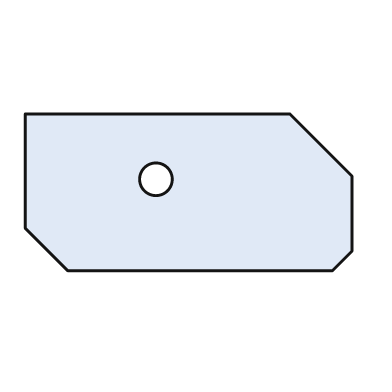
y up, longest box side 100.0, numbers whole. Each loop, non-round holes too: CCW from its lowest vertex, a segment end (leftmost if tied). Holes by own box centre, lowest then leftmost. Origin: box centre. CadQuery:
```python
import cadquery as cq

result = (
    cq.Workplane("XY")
    .moveTo(-37.0, -24.0)
    .lineTo(44.0, -24.0)
    .lineTo(50.0, -18.0)
    .lineTo(50.0, 5.0)
    .lineTo(31.0, 24.0)
    .lineTo(-50.0, 24.0)
    .lineTo(-50.0, -11.0)
    .close()
    .moveTo(-10.0, 4.0)
    .circle(5.0)
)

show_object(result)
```